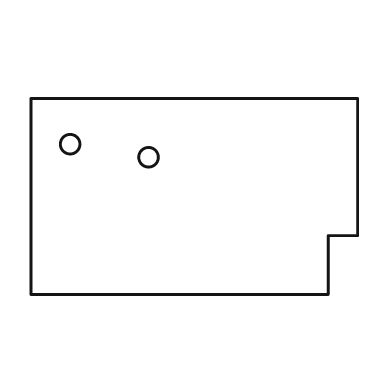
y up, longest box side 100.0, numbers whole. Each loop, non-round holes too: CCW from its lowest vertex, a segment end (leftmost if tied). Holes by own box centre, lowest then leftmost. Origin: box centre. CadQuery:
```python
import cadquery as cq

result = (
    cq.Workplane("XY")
    .moveTo(-50.0, -30.0)
    .lineTo(41.0, -30.0)
    .lineTo(41.0, -12.0)
    .lineTo(50.0, -12.0)
    .lineTo(50.0, 30.0)
    .lineTo(-50.0, 30.0)
    .close()
    .moveTo(-14.0, 12.0)
    .circle(3.0)
    .moveTo(-38.0, 16.0)
    .circle(3.0)
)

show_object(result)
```